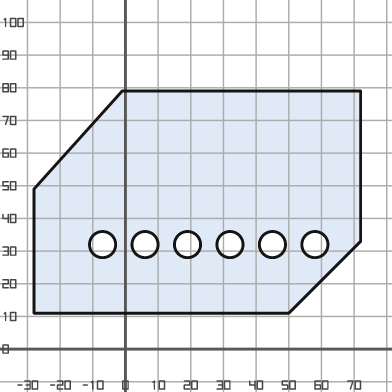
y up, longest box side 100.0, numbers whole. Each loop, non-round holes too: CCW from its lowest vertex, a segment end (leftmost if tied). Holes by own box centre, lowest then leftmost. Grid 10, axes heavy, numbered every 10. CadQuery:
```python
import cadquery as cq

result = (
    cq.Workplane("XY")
    .moveTo(-28.0, 11.0)
    .lineTo(50.0, 11.0)
    .lineTo(72.0, 33.0)
    .lineTo(72.0, 79.0)
    .lineTo(-1.0, 79.0)
    .lineTo(-28.0, 49.0)
    .close()
    .moveTo(-7.0, 32.0)
    .circle(4.0)
    .moveTo(6.0, 32.0)
    .circle(4.0)
    .moveTo(19.0, 32.0)
    .circle(4.0)
    .moveTo(32.0, 32.0)
    .circle(4.0)
    .moveTo(45.0, 32.0)
    .circle(4.0)
    .moveTo(58.0, 32.0)
    .circle(4.0)
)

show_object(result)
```